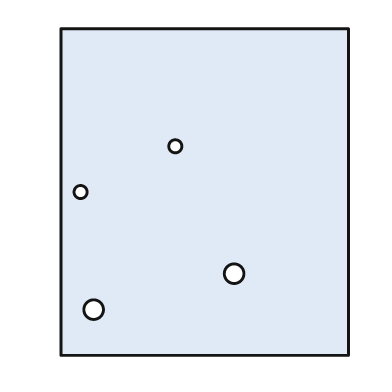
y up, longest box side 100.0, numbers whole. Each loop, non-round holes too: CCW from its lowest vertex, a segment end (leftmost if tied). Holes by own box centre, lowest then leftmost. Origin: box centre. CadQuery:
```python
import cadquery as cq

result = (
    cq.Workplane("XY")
    .moveTo(-44.0, -50.0)
    .lineTo(44.0, -50.0)
    .lineTo(44.0, 50.0)
    .lineTo(-44.0, 50.0)
    .close()
    .moveTo(-34.0, -36.0)
    .circle(3.0)
    .moveTo(9.0, -25.0)
    .circle(3.0)
    .moveTo(-38.0, 0.0)
    .circle(2.0)
    .moveTo(-9.0, 14.0)
    .circle(2.0)
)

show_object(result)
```